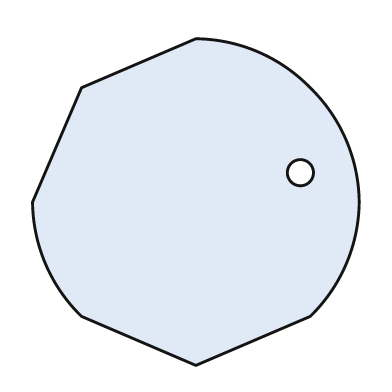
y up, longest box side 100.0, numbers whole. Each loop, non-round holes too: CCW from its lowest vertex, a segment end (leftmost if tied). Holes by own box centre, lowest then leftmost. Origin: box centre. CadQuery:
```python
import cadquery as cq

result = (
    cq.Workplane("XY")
    .moveTo(0.0, -50.0)
    .lineTo(35.0, -35.0)
    .threePointArc((46.0, -19.0), (50.0, 0.0))
    .threePointArc((46.0, 19.0), (35.0, 35.0))
    .threePointArc((19.0, 46.0), (0.0, 50.0))
    .lineTo(-35.0, 35.0)
    .lineTo(-50.0, 0.0)
    .threePointArc((-46.0, -19.0), (-35.0, -35.0))
    .close()
    .moveTo(32.0, 9.0)
    .circle(4.0)
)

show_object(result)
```